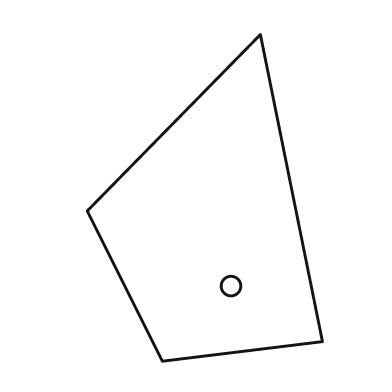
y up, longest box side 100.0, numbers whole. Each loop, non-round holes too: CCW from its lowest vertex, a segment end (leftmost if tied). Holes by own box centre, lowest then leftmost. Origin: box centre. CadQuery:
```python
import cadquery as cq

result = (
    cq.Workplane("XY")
    .moveTo(-13.0, -50.0)
    .lineTo(36.0, -44.0)
    .lineTo(17.0, 50.0)
    .lineTo(-36.0, -4.0)
    .close()
    .moveTo(8.0, -27.0)
    .circle(3.0)
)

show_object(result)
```